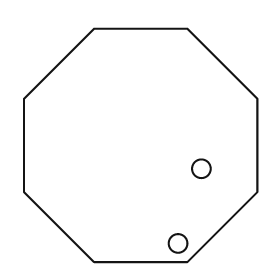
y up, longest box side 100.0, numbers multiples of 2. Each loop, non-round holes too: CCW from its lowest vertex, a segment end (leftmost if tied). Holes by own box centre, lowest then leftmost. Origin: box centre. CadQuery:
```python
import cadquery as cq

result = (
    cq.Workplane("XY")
    .moveTo(-20.0, -50.0)
    .lineTo(20.0, -50.0)
    .lineTo(50.0, -20.0)
    .lineTo(50.0, 20.0)
    .lineTo(20.0, 50.0)
    .lineTo(-20.0, 50.0)
    .lineTo(-50.0, 20.0)
    .lineTo(-50.0, -20.0)
    .close()
    .moveTo(16.0, -42.0)
    .circle(4.0)
    .moveTo(26.0, -10.0)
    .circle(4.0)
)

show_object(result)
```